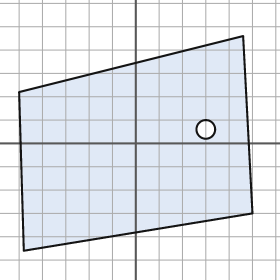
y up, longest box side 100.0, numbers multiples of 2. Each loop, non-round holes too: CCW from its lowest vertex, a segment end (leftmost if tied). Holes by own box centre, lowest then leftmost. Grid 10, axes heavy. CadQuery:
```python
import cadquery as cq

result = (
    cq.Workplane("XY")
    .moveTo(-48.0, -46.0)
    .lineTo(50.0, -30.0)
    .lineTo(46.0, 46.0)
    .lineTo(-50.0, 22.0)
    .close()
    .moveTo(30.0, 6.0)
    .circle(4.0)
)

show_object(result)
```